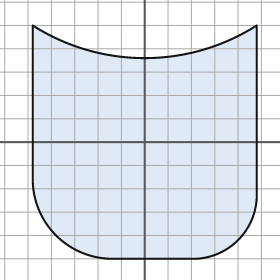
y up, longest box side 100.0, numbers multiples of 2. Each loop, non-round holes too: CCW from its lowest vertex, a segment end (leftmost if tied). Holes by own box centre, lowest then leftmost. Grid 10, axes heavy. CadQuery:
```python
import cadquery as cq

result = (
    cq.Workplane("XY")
    .moveTo(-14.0, -50.0)
    .lineTo(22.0, -50.0)
    .threePointArc((40.0, -42.0), (48.0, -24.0))
    .lineTo(48.0, 50.0)
    .threePointArc((0.0, 36.0), (-48.0, 50.0))
    .lineTo(-48.0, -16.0)
    .threePointArc((-38.0, -40.0), (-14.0, -50.0))
    .close()
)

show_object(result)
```